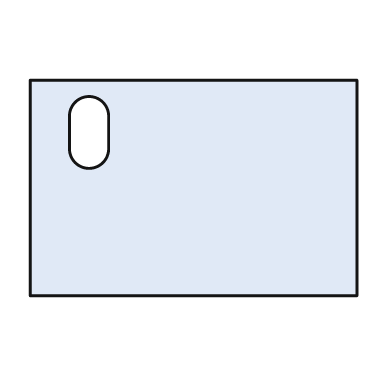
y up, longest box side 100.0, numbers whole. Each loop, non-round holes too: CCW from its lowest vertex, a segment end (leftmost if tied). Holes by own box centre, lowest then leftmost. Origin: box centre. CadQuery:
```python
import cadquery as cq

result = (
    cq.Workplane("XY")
    .moveTo(-50.0, -33.0)
    .lineTo(50.0, -33.0)
    .lineTo(50.0, 33.0)
    .lineTo(-50.0, 33.0)
    .close()
    .moveTo(-38.0, 12.0)
    .threePointArc((-32.0, 6.0), (-26.0, 12.0))
    .lineTo(-26.0, 22.0)
    .threePointArc((-32.0, 28.0), (-38.0, 22.0))
    .close()
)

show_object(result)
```